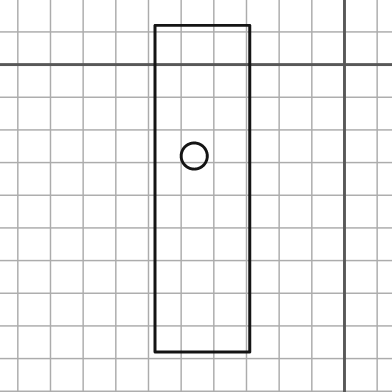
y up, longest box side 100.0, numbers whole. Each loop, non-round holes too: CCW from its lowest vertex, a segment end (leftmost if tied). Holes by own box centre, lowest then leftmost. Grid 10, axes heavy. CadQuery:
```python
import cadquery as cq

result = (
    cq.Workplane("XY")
    .moveTo(-58.0, -88.0)
    .lineTo(-29.0, -88.0)
    .lineTo(-29.0, 12.0)
    .lineTo(-58.0, 12.0)
    .close()
    .moveTo(-46.0, -28.0)
    .circle(4.0)
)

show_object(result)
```